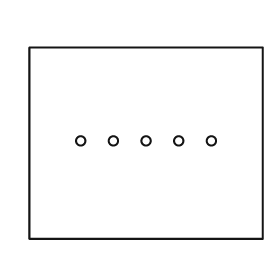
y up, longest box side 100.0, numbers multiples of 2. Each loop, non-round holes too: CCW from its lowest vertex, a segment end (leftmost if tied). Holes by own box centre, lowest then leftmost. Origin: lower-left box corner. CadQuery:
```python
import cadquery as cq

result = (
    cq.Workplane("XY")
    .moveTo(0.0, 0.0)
    .lineTo(100.0, 0.0)
    .lineTo(100.0, 82.0)
    .lineTo(0.0, 82.0)
    .close()
    .moveTo(22.0, 42.0)
    .circle(2.0)
    .moveTo(36.0, 42.0)
    .circle(2.0)
    .moveTo(50.0, 42.0)
    .circle(2.0)
    .moveTo(64.0, 42.0)
    .circle(2.0)
    .moveTo(78.0, 42.0)
    .circle(2.0)
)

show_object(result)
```